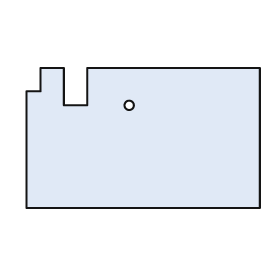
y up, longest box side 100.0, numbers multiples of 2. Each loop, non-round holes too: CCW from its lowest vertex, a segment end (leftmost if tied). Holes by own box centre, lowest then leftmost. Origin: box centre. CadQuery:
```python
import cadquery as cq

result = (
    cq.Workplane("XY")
    .moveTo(-50.0, -30.0)
    .lineTo(50.0, -30.0)
    .lineTo(50.0, 30.0)
    .lineTo(-24.0, 30.0)
    .lineTo(-24.0, 14.0)
    .lineTo(-34.0, 14.0)
    .lineTo(-34.0, 30.0)
    .lineTo(-44.0, 30.0)
    .lineTo(-44.0, 20.0)
    .lineTo(-50.0, 20.0)
    .close()
    .moveTo(-6.0, 14.0)
    .circle(2.0)
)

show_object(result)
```